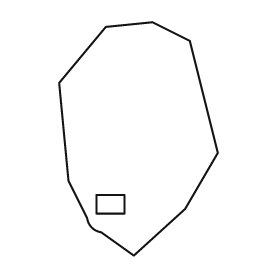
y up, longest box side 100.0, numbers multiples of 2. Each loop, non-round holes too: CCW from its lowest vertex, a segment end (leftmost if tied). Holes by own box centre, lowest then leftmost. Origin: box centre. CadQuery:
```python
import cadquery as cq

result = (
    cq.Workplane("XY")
    .moveTo(-2.0, -50.0)
    .lineTo(20.0, -30.0)
    .lineTo(34.0, -6.0)
    .lineTo(22.0, 42.0)
    .lineTo(6.0, 50.0)
    .lineTo(-14.0, 48.0)
    .lineTo(-34.0, 24.0)
    .lineTo(-30.0, -18.0)
    .lineTo(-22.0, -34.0)
    .threePointArc((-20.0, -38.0), (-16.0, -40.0))
    .close()
    .moveTo(-18.0, -32.0)
    .lineTo(-6.0, -32.0)
    .lineTo(-6.0, -24.0)
    .lineTo(-18.0, -24.0)
    .close()
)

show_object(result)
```